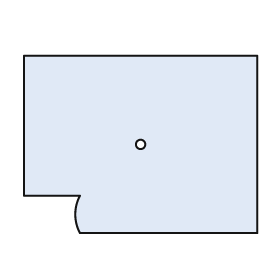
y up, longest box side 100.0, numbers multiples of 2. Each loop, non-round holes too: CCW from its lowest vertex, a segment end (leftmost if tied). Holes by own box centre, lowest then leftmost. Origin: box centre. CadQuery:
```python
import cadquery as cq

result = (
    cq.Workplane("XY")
    .moveTo(-26.0, -38.0)
    .lineTo(50.0, -38.0)
    .lineTo(50.0, 38.0)
    .lineTo(-50.0, 38.0)
    .lineTo(-50.0, -22.0)
    .lineTo(-26.0, -22.0)
    .threePointArc((-28.0, -30.0), (-26.0, -38.0))
    .close()
    .moveTo(0.0, 0.0)
    .circle(2.0)
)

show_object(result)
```